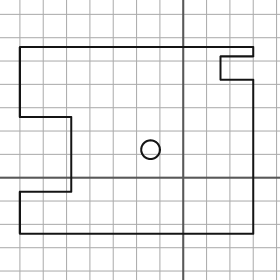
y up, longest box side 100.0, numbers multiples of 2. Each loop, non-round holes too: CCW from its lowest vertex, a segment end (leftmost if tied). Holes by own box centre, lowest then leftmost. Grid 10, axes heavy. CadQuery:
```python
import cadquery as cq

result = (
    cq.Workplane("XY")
    .moveTo(-70.0, -24.0)
    .lineTo(30.0, -24.0)
    .lineTo(30.0, 42.0)
    .lineTo(16.0, 42.0)
    .lineTo(16.0, 52.0)
    .lineTo(30.0, 52.0)
    .lineTo(30.0, 56.0)
    .lineTo(-70.0, 56.0)
    .lineTo(-70.0, 26.0)
    .lineTo(-48.0, 26.0)
    .lineTo(-48.0, -6.0)
    .lineTo(-70.0, -6.0)
    .close()
    .moveTo(-14.0, 12.0)
    .circle(4.0)
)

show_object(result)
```